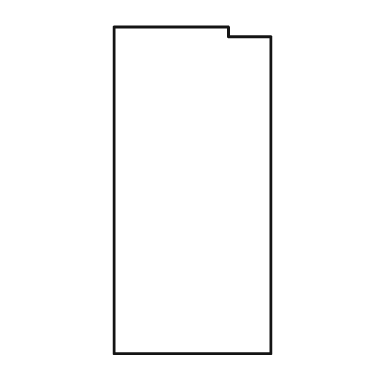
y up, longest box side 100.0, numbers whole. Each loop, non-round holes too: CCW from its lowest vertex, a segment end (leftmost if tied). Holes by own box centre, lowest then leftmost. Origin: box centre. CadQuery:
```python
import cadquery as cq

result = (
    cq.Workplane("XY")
    .moveTo(-24.0, -50.0)
    .lineTo(24.0, -50.0)
    .lineTo(24.0, 47.0)
    .lineTo(11.0, 47.0)
    .lineTo(11.0, 50.0)
    .lineTo(-24.0, 50.0)
    .close()
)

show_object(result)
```